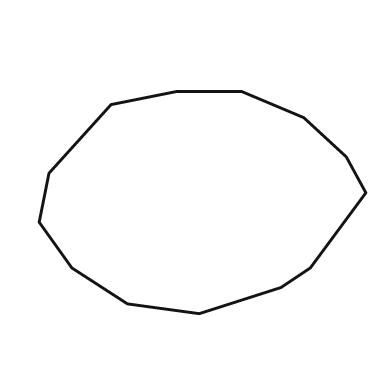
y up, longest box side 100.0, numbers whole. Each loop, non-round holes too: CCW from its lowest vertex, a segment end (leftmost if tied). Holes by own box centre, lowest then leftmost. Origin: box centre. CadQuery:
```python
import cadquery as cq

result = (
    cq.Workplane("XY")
    .moveTo(-1.0, -34.0)
    .lineTo(24.0, -26.0)
    .lineTo(33.0, -20.0)
    .lineTo(50.0, 3.0)
    .lineTo(44.0, 14.0)
    .lineTo(31.0, 26.0)
    .lineTo(12.0, 34.0)
    .lineTo(-8.0, 34.0)
    .lineTo(-28.0, 30.0)
    .lineTo(-47.0, 9.0)
    .lineTo(-50.0, -6.0)
    .lineTo(-40.0, -20.0)
    .lineTo(-23.0, -31.0)
    .close()
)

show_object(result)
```